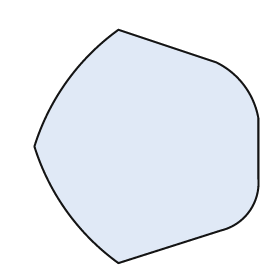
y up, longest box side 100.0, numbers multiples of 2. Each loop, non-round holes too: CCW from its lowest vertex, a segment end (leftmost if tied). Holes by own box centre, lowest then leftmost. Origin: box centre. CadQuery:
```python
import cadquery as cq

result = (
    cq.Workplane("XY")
    .moveTo(-12.0, -50.0)
    .lineTo(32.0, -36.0)
    .threePointArc((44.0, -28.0), (48.0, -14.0))
    .lineTo(48.0, 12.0)
    .threePointArc((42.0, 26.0), (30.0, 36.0))
    .lineTo(-12.0, 50.0)
    .threePointArc((-34.0, 28.0), (-48.0, 0.0))
    .threePointArc((-34.0, -28.0), (-12.0, -50.0))
    .close()
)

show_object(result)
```